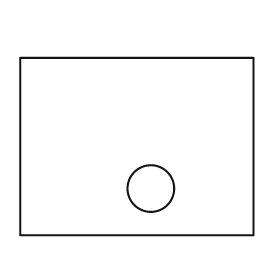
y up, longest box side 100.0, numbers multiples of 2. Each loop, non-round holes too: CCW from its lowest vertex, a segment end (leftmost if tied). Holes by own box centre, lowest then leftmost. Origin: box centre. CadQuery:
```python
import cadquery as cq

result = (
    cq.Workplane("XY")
    .moveTo(-50.0, -38.0)
    .lineTo(50.0, -38.0)
    .lineTo(50.0, 38.0)
    .lineTo(-50.0, 38.0)
    .close()
    .moveTo(6.0, -18.0)
    .circle(10.0)
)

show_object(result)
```